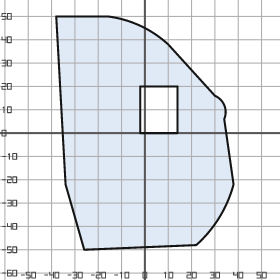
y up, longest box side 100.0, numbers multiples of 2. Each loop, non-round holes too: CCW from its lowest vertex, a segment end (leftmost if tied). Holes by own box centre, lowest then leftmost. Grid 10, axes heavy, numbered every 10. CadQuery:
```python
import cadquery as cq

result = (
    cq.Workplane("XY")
    .moveTo(-26.0, -50.0)
    .lineTo(22.0, -48.0)
    .threePointArc((32.0, -36.0), (38.0, -22.0))
    .lineTo(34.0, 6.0)
    .threePointArc((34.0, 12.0), (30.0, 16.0))
    .lineTo(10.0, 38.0)
    .threePointArc((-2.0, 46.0), (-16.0, 50.0))
    .lineTo(-38.0, 50.0)
    .lineTo(-34.0, -22.0)
    .close()
    .moveTo(-2.0, 0.0)
    .lineTo(14.0, 0.0)
    .lineTo(14.0, 20.0)
    .lineTo(-2.0, 20.0)
    .close()
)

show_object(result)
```